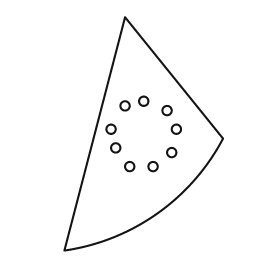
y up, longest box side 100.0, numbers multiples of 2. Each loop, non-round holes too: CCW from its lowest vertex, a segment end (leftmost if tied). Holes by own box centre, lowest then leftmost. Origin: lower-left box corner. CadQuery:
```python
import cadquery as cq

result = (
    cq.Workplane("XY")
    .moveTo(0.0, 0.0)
    .threePointArc((40.0, 16.0), (68.0, 48.0))
    .lineTo(26.0, 100.0)
    .close()
    .moveTo(28.0, 36.0)
    .circle(2.0)
    .moveTo(38.0, 36.0)
    .circle(2.0)
    .moveTo(46.0, 42.0)
    .circle(2.0)
    .moveTo(22.0, 44.0)
    .circle(2.0)
    .moveTo(20.0, 52.0)
    .circle(2.0)
    .moveTo(48.0, 52.0)
    .circle(2.0)
    .moveTo(44.0, 60.0)
    .circle(2.0)
    .moveTo(26.0, 62.0)
    .circle(2.0)
    .moveTo(34.0, 64.0)
    .circle(2.0)
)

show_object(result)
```